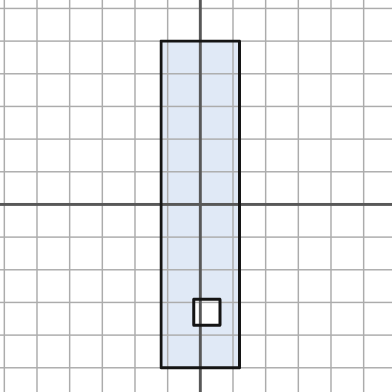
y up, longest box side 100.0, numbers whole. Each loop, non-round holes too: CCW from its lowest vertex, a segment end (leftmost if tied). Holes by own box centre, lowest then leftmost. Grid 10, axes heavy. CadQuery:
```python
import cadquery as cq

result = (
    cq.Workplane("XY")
    .moveTo(-12.0, -50.0)
    .lineTo(12.0, -50.0)
    .lineTo(12.0, 50.0)
    .lineTo(-12.0, 50.0)
    .close()
    .moveTo(-2.0, -37.0)
    .lineTo(6.0, -37.0)
    .lineTo(6.0, -29.0)
    .lineTo(-2.0, -29.0)
    .close()
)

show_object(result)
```